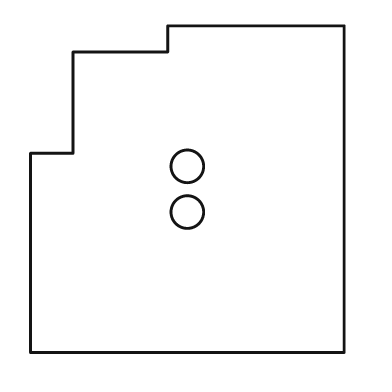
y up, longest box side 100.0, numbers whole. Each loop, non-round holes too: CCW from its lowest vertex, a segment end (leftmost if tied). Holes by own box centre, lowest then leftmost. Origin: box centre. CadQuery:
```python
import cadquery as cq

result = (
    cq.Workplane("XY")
    .moveTo(-48.0, -50.0)
    .lineTo(48.0, -50.0)
    .lineTo(48.0, 50.0)
    .lineTo(-6.0, 50.0)
    .lineTo(-6.0, 42.0)
    .lineTo(-35.0, 42.0)
    .lineTo(-35.0, 11.0)
    .lineTo(-48.0, 11.0)
    .close()
    .moveTo(0.0, -7.0)
    .circle(5.0)
    .moveTo(0.0, 7.0)
    .circle(5.0)
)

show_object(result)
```